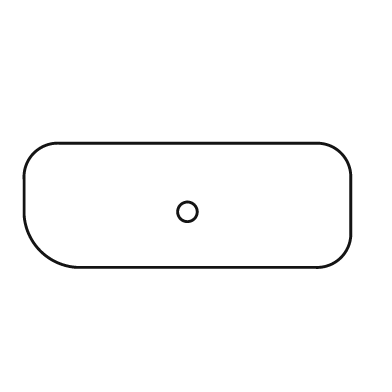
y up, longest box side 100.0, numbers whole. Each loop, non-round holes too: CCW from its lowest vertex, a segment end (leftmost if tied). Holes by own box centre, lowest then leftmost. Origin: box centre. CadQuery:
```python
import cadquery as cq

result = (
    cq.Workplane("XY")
    .moveTo(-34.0, -19.0)
    .lineTo(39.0, -19.0)
    .threePointArc((47.0, -16.0), (50.0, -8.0))
    .lineTo(50.0, 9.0)
    .threePointArc((47.0, 16.0), (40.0, 19.0))
    .lineTo(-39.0, 19.0)
    .threePointArc((-47.0, 16.0), (-50.0, 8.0))
    .lineTo(-50.0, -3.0)
    .threePointArc((-45.0, -14.0), (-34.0, -19.0))
    .close()
    .moveTo(0.0, -2.0)
    .circle(3.0)
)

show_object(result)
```